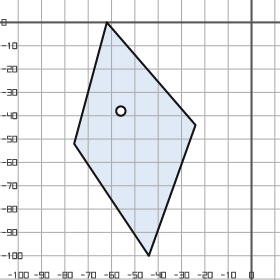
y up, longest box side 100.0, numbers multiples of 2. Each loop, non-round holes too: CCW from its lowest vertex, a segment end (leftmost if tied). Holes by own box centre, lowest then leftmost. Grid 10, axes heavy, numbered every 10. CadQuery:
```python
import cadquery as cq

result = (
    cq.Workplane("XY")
    .moveTo(-44.0, -100.0)
    .lineTo(-24.0, -44.0)
    .lineTo(-62.0, 0.0)
    .lineTo(-76.0, -52.0)
    .close()
    .moveTo(-56.0, -38.0)
    .circle(2.0)
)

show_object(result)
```